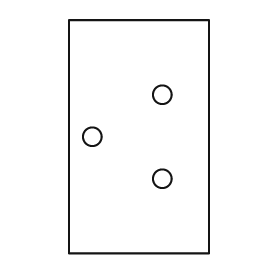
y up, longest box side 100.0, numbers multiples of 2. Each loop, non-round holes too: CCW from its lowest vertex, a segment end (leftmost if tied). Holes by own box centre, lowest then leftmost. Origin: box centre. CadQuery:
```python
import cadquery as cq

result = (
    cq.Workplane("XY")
    .moveTo(-30.0, -50.0)
    .lineTo(30.0, -50.0)
    .lineTo(30.0, 50.0)
    .lineTo(-30.0, 50.0)
    .close()
    .moveTo(10.0, -18.0)
    .circle(4.0)
    .moveTo(-20.0, 0.0)
    .circle(4.0)
    .moveTo(10.0, 18.0)
    .circle(4.0)
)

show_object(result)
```